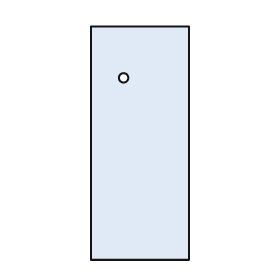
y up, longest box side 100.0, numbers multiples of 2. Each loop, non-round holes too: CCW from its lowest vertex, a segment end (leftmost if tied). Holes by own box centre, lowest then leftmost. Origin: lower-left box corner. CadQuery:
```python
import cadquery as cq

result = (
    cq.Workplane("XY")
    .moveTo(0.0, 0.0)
    .lineTo(42.0, 0.0)
    .lineTo(42.0, 100.0)
    .lineTo(0.0, 100.0)
    .close()
    .moveTo(14.0, 78.0)
    .circle(2.0)
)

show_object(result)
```